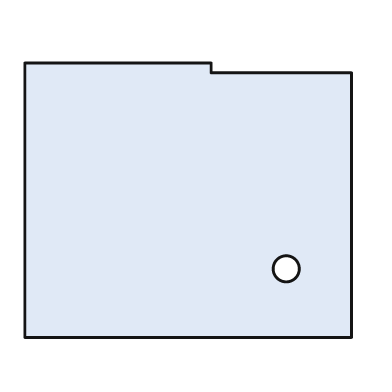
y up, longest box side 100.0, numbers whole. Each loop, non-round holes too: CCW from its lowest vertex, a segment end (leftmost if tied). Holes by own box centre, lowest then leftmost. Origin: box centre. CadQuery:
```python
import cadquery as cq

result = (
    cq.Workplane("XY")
    .moveTo(-50.0, -42.0)
    .lineTo(50.0, -42.0)
    .lineTo(50.0, 39.0)
    .lineTo(7.0, 39.0)
    .lineTo(7.0, 42.0)
    .lineTo(-50.0, 42.0)
    .close()
    .moveTo(30.0, -21.0)
    .circle(4.0)
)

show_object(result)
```